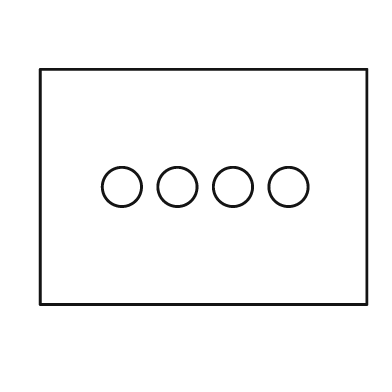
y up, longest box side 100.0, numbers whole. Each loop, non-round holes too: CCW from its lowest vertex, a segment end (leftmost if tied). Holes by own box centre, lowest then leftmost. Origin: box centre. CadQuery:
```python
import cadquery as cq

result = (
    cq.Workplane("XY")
    .moveTo(-50.0, -36.0)
    .lineTo(50.0, -36.0)
    .lineTo(50.0, 36.0)
    .lineTo(-50.0, 36.0)
    .close()
    .moveTo(-25.0, 0.0)
    .circle(6.0)
    .moveTo(-8.0, 0.0)
    .circle(6.0)
    .moveTo(9.0, 0.0)
    .circle(6.0)
    .moveTo(26.0, 0.0)
    .circle(6.0)
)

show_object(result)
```